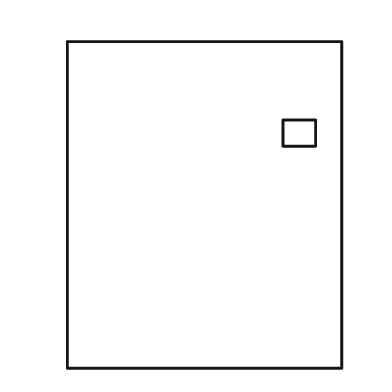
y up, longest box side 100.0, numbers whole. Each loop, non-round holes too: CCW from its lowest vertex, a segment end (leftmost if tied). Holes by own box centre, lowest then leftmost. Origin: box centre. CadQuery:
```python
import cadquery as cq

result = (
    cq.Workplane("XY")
    .moveTo(-42.0, -50.0)
    .lineTo(42.0, -50.0)
    .lineTo(42.0, 50.0)
    .lineTo(-42.0, 50.0)
    .close()
    .moveTo(24.0, 18.0)
    .lineTo(34.0, 18.0)
    .lineTo(34.0, 26.0)
    .lineTo(24.0, 26.0)
    .close()
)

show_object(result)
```